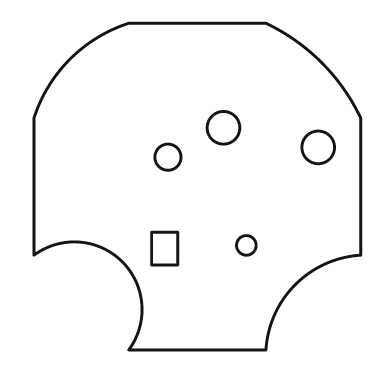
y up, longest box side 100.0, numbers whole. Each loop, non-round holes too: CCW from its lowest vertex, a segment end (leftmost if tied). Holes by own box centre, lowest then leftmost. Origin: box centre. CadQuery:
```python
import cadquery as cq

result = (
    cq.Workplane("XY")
    .moveTo(-21.0, -50.0)
    .lineTo(21.0, -50.0)
    .threePointArc((30.0, -30.0), (50.0, -21.0))
    .lineTo(50.0, 21.0)
    .threePointArc((38.0, 38.0), (21.0, 50.0))
    .lineTo(-21.0, 50.0)
    .threePointArc((-39.0, 39.0), (-50.0, 21.0))
    .lineTo(-50.0, -21.0)
    .threePointArc((-23.0, -23.0), (-21.0, -50.0))
    .close()
    .moveTo(-14.0, -24.0)
    .lineTo(-6.0, -24.0)
    .lineTo(-6.0, -14.0)
    .lineTo(-14.0, -14.0)
    .close()
    .moveTo(15.0, -18.0)
    .circle(3.0)
    .moveTo(-9.0, 9.0)
    .circle(4.0)
    .moveTo(37.0, 12.0)
    .circle(5.0)
    .moveTo(8.0, 18.0)
    .circle(5.0)
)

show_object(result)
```